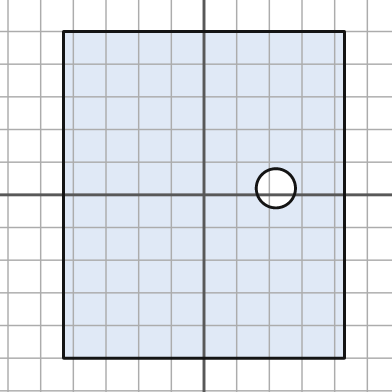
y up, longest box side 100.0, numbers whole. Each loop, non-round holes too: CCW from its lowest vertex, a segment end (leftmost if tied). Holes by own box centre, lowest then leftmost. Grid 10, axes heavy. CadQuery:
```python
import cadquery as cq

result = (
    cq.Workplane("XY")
    .moveTo(-43.0, -50.0)
    .lineTo(43.0, -50.0)
    .lineTo(43.0, 50.0)
    .lineTo(-43.0, 50.0)
    .close()
    .moveTo(22.0, 2.0)
    .circle(6.0)
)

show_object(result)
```